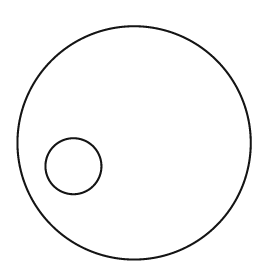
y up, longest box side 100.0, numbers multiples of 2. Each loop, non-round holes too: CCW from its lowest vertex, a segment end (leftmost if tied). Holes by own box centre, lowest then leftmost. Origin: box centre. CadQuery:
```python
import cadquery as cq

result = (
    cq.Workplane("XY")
    .moveTo(0.0, 0.0)
    .circle(50.0)
    .moveTo(-26.0, -10.0)
    .circle(12.0)
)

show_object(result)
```